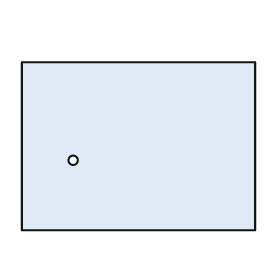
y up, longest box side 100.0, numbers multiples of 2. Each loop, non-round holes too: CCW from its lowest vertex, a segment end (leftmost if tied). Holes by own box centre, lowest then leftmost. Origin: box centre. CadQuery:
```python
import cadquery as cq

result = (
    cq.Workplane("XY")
    .moveTo(-50.0, -36.0)
    .lineTo(50.0, -36.0)
    .lineTo(50.0, 36.0)
    .lineTo(-50.0, 36.0)
    .close()
    .moveTo(-28.0, -6.0)
    .circle(2.0)
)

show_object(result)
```